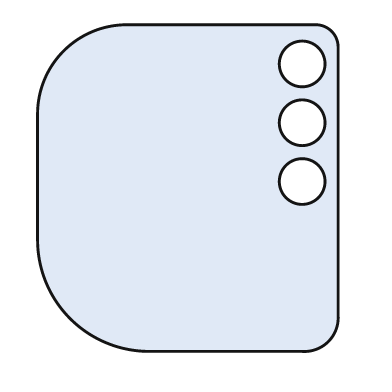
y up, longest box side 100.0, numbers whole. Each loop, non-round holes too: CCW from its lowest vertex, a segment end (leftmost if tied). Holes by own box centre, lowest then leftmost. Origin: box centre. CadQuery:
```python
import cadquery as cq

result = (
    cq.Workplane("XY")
    .moveTo(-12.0, -50.0)
    .lineTo(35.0, -50.0)
    .threePointArc((43.0, -47.0), (46.0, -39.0))
    .lineTo(46.0, 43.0)
    .threePointArc((44.0, 48.0), (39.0, 50.0))
    .lineTo(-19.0, 50.0)
    .threePointArc((-38.0, 42.0), (-46.0, 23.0))
    .lineTo(-46.0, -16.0)
    .threePointArc((-36.0, -40.0), (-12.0, -50.0))
    .close()
    .moveTo(35.0, 2.0)
    .circle(7.0)
    .moveTo(35.0, 20.0)
    .circle(7.0)
    .moveTo(35.0, 38.0)
    .circle(7.0)
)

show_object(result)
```